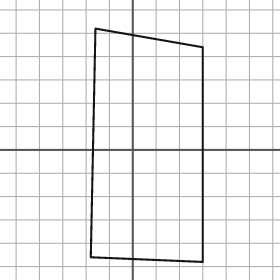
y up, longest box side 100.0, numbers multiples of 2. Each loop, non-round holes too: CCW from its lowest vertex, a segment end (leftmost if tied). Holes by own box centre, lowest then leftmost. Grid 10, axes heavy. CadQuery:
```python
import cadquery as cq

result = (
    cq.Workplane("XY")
    .moveTo(30.0, -48.0)
    .lineTo(30.0, 44.0)
    .lineTo(-16.0, 52.0)
    .lineTo(-18.0, -46.0)
    .close()
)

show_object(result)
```